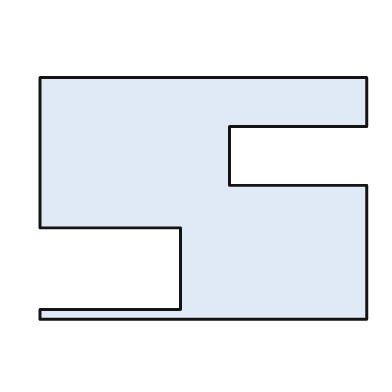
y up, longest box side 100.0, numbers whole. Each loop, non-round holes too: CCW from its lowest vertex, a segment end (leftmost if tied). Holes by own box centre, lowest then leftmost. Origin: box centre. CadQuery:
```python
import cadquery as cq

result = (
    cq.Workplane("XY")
    .moveTo(-50.0, -37.0)
    .lineTo(50.0, -37.0)
    .lineTo(50.0, 4.0)
    .lineTo(8.0, 4.0)
    .lineTo(8.0, 22.0)
    .lineTo(50.0, 22.0)
    .lineTo(50.0, 37.0)
    .lineTo(-50.0, 37.0)
    .lineTo(-50.0, -9.0)
    .lineTo(-7.0, -9.0)
    .lineTo(-7.0, -34.0)
    .lineTo(-50.0, -34.0)
    .close()
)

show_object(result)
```